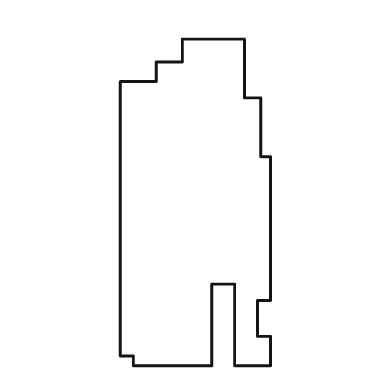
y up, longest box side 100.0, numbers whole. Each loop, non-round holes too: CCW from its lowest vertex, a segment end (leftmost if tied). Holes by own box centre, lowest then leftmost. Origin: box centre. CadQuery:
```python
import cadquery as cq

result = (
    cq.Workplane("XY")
    .moveTo(-19.0, -50.0)
    .lineTo(5.0, -50.0)
    .lineTo(5.0, -25.0)
    .lineTo(12.0, -25.0)
    .lineTo(12.0, -50.0)
    .lineTo(23.0, -50.0)
    .lineTo(23.0, -41.0)
    .lineTo(19.0, -41.0)
    .lineTo(19.0, -30.0)
    .lineTo(23.0, -30.0)
    .lineTo(23.0, 14.0)
    .lineTo(20.0, 14.0)
    .lineTo(20.0, 32.0)
    .lineTo(15.0, 32.0)
    .lineTo(15.0, 50.0)
    .lineTo(-4.0, 50.0)
    .lineTo(-4.0, 43.0)
    .lineTo(-12.0, 43.0)
    .lineTo(-12.0, 37.0)
    .lineTo(-23.0, 37.0)
    .lineTo(-23.0, -47.0)
    .lineTo(-19.0, -47.0)
    .close()
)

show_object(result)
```